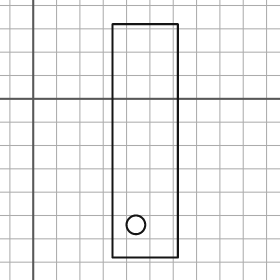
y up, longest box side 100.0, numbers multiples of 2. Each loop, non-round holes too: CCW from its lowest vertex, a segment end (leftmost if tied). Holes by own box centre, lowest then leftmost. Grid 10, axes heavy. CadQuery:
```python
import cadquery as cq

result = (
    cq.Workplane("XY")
    .moveTo(34.0, -68.0)
    .lineTo(62.0, -68.0)
    .lineTo(62.0, 32.0)
    .lineTo(34.0, 32.0)
    .close()
    .moveTo(44.0, -54.0)
    .circle(4.0)
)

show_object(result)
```